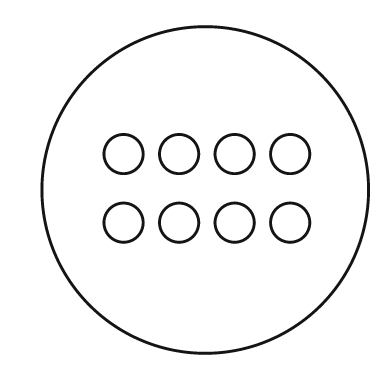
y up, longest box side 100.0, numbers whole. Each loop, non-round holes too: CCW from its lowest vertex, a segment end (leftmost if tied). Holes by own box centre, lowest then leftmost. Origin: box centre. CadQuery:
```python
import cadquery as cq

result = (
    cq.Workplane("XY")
    .moveTo(0.0, 0.0)
    .circle(50.0)
    .moveTo(-25.0, -10.0)
    .circle(6.0)
    .moveTo(-8.0, -10.0)
    .circle(6.0)
    .moveTo(9.0, -10.0)
    .circle(6.0)
    .moveTo(26.0, -10.0)
    .circle(6.0)
    .moveTo(-25.0, 11.0)
    .circle(6.0)
    .moveTo(-8.0, 11.0)
    .circle(6.0)
    .moveTo(9.0, 11.0)
    .circle(6.0)
    .moveTo(26.0, 11.0)
    .circle(6.0)
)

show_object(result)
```